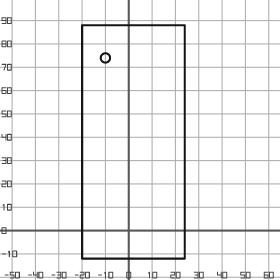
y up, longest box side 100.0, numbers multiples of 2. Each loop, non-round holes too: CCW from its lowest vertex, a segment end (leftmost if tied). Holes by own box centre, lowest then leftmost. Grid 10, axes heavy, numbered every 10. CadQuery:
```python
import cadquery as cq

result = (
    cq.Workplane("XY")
    .moveTo(-20.0, -12.0)
    .lineTo(24.0, -12.0)
    .lineTo(24.0, 88.0)
    .lineTo(-20.0, 88.0)
    .close()
    .moveTo(-10.0, 74.0)
    .circle(2.0)
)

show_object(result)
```